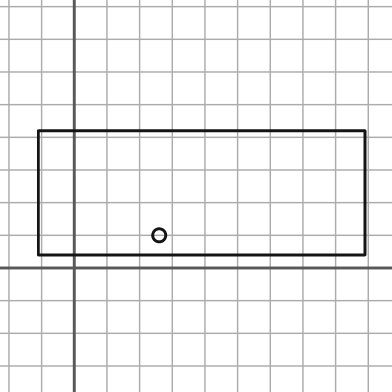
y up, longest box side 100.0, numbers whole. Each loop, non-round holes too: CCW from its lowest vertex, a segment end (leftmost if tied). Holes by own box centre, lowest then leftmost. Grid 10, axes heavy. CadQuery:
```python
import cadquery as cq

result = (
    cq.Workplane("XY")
    .moveTo(-11.0, 4.0)
    .lineTo(89.0, 4.0)
    .lineTo(89.0, 42.0)
    .lineTo(-11.0, 42.0)
    .close()
    .moveTo(26.0, 10.0)
    .circle(2.0)
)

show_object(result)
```